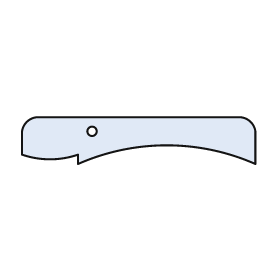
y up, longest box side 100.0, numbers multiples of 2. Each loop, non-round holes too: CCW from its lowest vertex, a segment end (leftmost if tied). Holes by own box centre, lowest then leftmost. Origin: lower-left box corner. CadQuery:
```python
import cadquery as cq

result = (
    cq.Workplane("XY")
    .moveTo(24.0, 0.0)
    .threePointArc((62.0, 8.0), (100.0, 0.0))
    .lineTo(100.0, 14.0)
    .threePointArc((98.0, 18.0), (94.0, 20.0))
    .lineTo(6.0, 20.0)
    .threePointArc((2.0, 18.0), (0.0, 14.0))
    .lineTo(0.0, 4.0)
    .threePointArc((12.0, 2.0), (24.0, 4.0))
    .close()
    .moveTo(30.0, 14.0)
    .circle(2.0)
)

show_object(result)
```